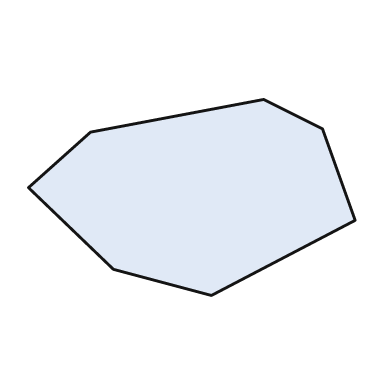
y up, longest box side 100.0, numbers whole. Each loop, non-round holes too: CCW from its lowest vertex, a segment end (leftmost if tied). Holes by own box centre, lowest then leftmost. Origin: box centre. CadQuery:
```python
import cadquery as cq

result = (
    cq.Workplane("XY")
    .moveTo(6.0, -30.0)
    .lineTo(50.0, -7.0)
    .lineTo(40.0, 21.0)
    .lineTo(22.0, 30.0)
    .lineTo(-31.0, 20.0)
    .lineTo(-50.0, 3.0)
    .lineTo(-24.0, -22.0)
    .close()
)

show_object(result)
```